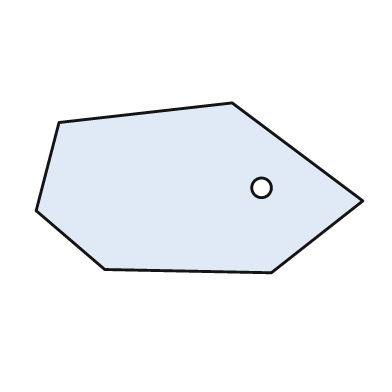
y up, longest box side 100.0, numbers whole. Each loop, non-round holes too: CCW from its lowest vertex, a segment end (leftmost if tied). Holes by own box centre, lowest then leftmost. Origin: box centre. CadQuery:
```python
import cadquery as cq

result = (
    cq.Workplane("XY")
    .moveTo(22.0, -26.0)
    .lineTo(50.0, -4.0)
    .lineTo(10.0, 26.0)
    .lineTo(-43.0, 20.0)
    .lineTo(-50.0, -7.0)
    .lineTo(-29.0, -25.0)
    .close()
    .moveTo(19.0, 0.0)
    .circle(3.0)
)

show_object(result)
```